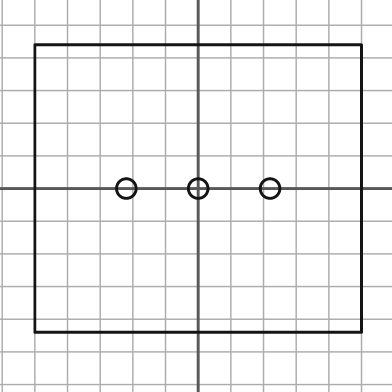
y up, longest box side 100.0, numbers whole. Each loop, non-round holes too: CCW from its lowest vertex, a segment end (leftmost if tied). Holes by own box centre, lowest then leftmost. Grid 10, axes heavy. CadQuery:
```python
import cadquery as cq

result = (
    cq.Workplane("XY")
    .moveTo(-50.0, -44.0)
    .lineTo(50.0, -44.0)
    .lineTo(50.0, 44.0)
    .lineTo(-50.0, 44.0)
    .close()
    .moveTo(-22.0, 0.0)
    .circle(3.0)
    .moveTo(0.0, 0.0)
    .circle(3.0)
    .moveTo(22.0, 0.0)
    .circle(3.0)
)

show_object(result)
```